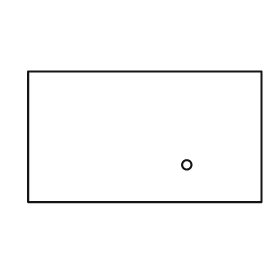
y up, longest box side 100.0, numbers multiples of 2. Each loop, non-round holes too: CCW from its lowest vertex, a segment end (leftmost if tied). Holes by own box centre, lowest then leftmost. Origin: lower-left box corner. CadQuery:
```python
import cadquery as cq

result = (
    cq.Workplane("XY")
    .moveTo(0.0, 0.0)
    .lineTo(100.0, 0.0)
    .lineTo(100.0, 56.0)
    .lineTo(0.0, 56.0)
    .close()
    .moveTo(68.0, 16.0)
    .circle(2.0)
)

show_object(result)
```